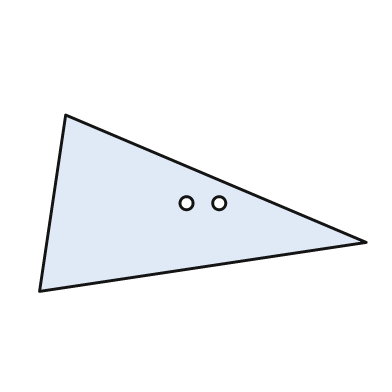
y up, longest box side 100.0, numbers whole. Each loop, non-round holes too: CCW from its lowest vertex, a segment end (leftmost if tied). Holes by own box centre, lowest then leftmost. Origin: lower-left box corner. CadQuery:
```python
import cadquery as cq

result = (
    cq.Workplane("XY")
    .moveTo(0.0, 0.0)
    .lineTo(100.0, 15.0)
    .lineTo(8.0, 54.0)
    .close()
    .moveTo(45.0, 27.0)
    .circle(2.0)
    .moveTo(55.0, 27.0)
    .circle(2.0)
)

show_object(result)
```